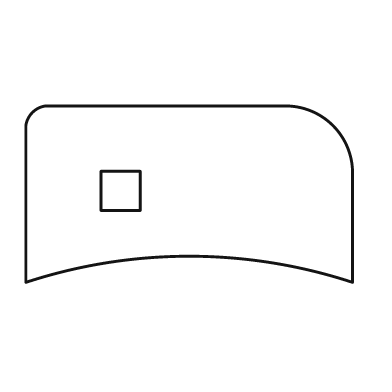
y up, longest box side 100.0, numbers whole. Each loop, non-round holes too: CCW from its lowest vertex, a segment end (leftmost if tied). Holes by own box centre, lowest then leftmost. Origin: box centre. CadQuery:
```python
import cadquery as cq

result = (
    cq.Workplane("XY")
    .moveTo(-50.0, -27.0)
    .threePointArc((0.0, -19.0), (50.0, -27.0))
    .lineTo(50.0, 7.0)
    .threePointArc((44.0, 21.0), (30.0, 27.0))
    .lineTo(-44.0, 27.0)
    .threePointArc((-48.0, 25.0), (-50.0, 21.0))
    .close()
    .moveTo(-27.0, -5.0)
    .lineTo(-15.0, -5.0)
    .lineTo(-15.0, 7.0)
    .lineTo(-27.0, 7.0)
    .close()
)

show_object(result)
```